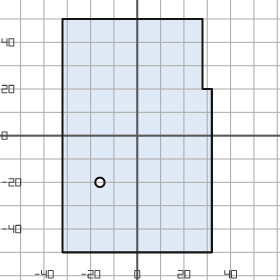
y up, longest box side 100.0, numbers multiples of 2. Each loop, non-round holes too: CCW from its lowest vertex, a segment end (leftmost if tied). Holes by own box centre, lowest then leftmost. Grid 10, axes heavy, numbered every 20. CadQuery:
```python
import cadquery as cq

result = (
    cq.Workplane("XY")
    .moveTo(-32.0, -50.0)
    .lineTo(32.0, -50.0)
    .lineTo(32.0, 20.0)
    .lineTo(28.0, 20.0)
    .lineTo(28.0, 50.0)
    .lineTo(-32.0, 50.0)
    .close()
    .moveTo(-16.0, -20.0)
    .circle(2.0)
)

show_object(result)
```